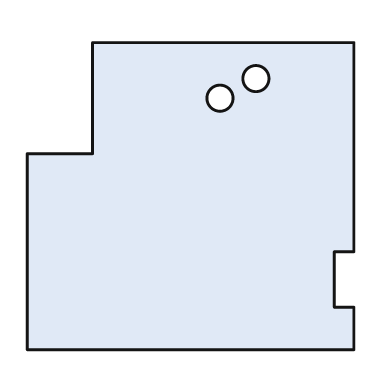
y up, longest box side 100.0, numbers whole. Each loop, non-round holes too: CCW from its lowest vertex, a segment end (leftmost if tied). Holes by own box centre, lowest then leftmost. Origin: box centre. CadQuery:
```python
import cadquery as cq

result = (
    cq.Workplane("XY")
    .moveTo(-50.0, -47.0)
    .lineTo(50.0, -47.0)
    .lineTo(50.0, -34.0)
    .lineTo(44.0, -34.0)
    .lineTo(44.0, -17.0)
    .lineTo(50.0, -17.0)
    .lineTo(50.0, 47.0)
    .lineTo(-30.0, 47.0)
    .lineTo(-30.0, 13.0)
    .lineTo(-50.0, 13.0)
    .close()
    .moveTo(9.0, 30.0)
    .circle(4.0)
    .moveTo(20.0, 36.0)
    .circle(4.0)
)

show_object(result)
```